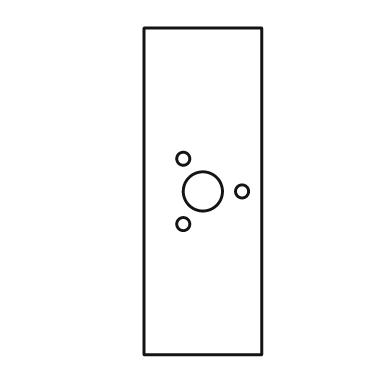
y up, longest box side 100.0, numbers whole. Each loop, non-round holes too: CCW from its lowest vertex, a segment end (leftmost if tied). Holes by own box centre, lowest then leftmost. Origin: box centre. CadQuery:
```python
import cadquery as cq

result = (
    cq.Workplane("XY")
    .moveTo(-18.0, -50.0)
    .lineTo(18.0, -50.0)
    .lineTo(18.0, 50.0)
    .lineTo(-18.0, 50.0)
    .close()
    .moveTo(-6.0, -10.0)
    .circle(2.0)
    .moveTo(0.0, 0.0)
    .circle(6.0)
    .moveTo(12.0, 0.0)
    .circle(2.0)
    .moveTo(-6.0, 10.0)
    .circle(2.0)
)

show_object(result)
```